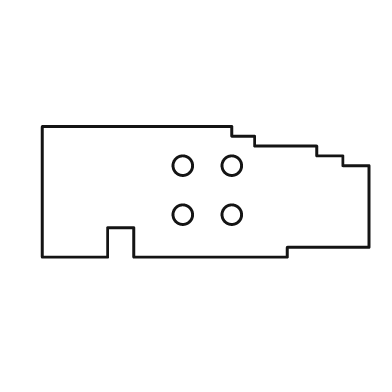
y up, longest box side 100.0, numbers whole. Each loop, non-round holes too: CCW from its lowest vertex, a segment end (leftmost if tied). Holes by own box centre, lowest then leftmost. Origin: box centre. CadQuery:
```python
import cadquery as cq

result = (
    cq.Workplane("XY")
    .moveTo(-50.0, -20.0)
    .lineTo(-30.0, -20.0)
    .lineTo(-30.0, -11.0)
    .lineTo(-22.0, -11.0)
    .lineTo(-22.0, -20.0)
    .lineTo(25.0, -20.0)
    .lineTo(25.0, -17.0)
    .lineTo(50.0, -17.0)
    .lineTo(50.0, 8.0)
    .lineTo(42.0, 8.0)
    .lineTo(42.0, 11.0)
    .lineTo(34.0, 11.0)
    .lineTo(34.0, 14.0)
    .lineTo(15.0, 14.0)
    .lineTo(15.0, 17.0)
    .lineTo(8.0, 17.0)
    .lineTo(8.0, 20.0)
    .lineTo(-50.0, 20.0)
    .close()
    .moveTo(-7.0, -7.0)
    .circle(3.0)
    .moveTo(8.0, -7.0)
    .circle(3.0)
    .moveTo(-7.0, 8.0)
    .circle(3.0)
    .moveTo(8.0, 8.0)
    .circle(3.0)
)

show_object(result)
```